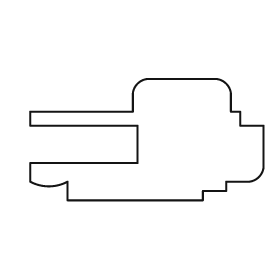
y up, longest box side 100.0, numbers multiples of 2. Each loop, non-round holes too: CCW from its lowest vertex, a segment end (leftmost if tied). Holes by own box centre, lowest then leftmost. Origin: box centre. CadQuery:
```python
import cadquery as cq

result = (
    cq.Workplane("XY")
    .moveTo(-34.0, -26.0)
    .lineTo(24.0, -26.0)
    .lineTo(24.0, -22.0)
    .lineTo(34.0, -22.0)
    .lineTo(34.0, -18.0)
    .lineTo(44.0, -18.0)
    .threePointArc((48.0, -16.0), (50.0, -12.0))
    .lineTo(50.0, 6.0)
    .lineTo(40.0, 6.0)
    .lineTo(40.0, 12.0)
    .lineTo(36.0, 12.0)
    .lineTo(36.0, 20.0)
    .threePointArc((34.0, 24.0), (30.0, 26.0))
    .lineTo(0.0, 26.0)
    .threePointArc((-4.0, 24.0), (-6.0, 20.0))
    .lineTo(-6.0, 12.0)
    .lineTo(-50.0, 12.0)
    .lineTo(-50.0, 6.0)
    .lineTo(-4.0, 6.0)
    .lineTo(-4.0, -10.0)
    .lineTo(-50.0, -10.0)
    .lineTo(-50.0, -18.0)
    .threePointArc((-42.0, -20.0), (-34.0, -18.0))
    .close()
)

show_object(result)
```